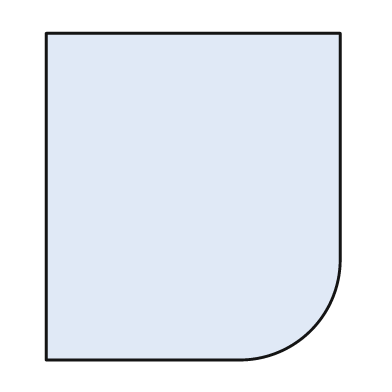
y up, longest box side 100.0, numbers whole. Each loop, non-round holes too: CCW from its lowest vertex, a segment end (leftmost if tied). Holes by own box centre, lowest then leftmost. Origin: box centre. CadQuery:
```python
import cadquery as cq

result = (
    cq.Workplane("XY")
    .moveTo(-45.0, -50.0)
    .lineTo(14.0, -50.0)
    .threePointArc((36.0, -41.0), (45.0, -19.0))
    .lineTo(45.0, 50.0)
    .lineTo(-45.0, 50.0)
    .close()
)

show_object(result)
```